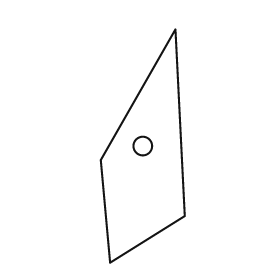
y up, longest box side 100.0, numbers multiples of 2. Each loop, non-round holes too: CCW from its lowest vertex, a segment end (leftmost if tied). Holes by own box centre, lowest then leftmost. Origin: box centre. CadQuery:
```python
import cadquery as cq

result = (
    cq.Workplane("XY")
    .moveTo(-14.0, -50.0)
    .lineTo(18.0, -30.0)
    .lineTo(14.0, 50.0)
    .lineTo(-18.0, -6.0)
    .close()
    .moveTo(0.0, 0.0)
    .circle(4.0)
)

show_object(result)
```